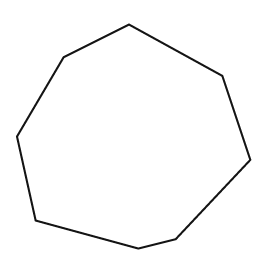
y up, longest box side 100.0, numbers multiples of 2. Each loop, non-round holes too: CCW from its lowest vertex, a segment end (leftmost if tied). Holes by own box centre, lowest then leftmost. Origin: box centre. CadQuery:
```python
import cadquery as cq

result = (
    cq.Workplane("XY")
    .moveTo(2.0, -48.0)
    .lineTo(18.0, -44.0)
    .lineTo(50.0, -10.0)
    .lineTo(38.0, 26.0)
    .lineTo(-2.0, 48.0)
    .lineTo(-30.0, 34.0)
    .lineTo(-50.0, 0.0)
    .lineTo(-42.0, -36.0)
    .close()
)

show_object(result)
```